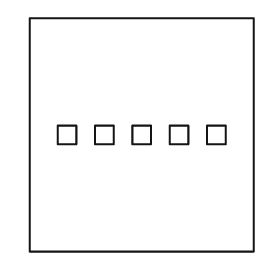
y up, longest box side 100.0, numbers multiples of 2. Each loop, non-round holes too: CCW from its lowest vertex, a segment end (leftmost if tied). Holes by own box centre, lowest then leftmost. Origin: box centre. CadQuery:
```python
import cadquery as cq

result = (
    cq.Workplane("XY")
    .moveTo(-48.0, -50.0)
    .lineTo(48.0, -50.0)
    .lineTo(48.0, 50.0)
    .lineTo(-48.0, 50.0)
    .close()
    .moveTo(-36.0, -4.0)
    .lineTo(-28.0, -4.0)
    .lineTo(-28.0, 4.0)
    .lineTo(-36.0, 4.0)
    .close()
    .moveTo(-20.0, -4.0)
    .lineTo(-12.0, -4.0)
    .lineTo(-12.0, 4.0)
    .lineTo(-20.0, 4.0)
    .close()
    .moveTo(-4.0, -4.0)
    .lineTo(4.0, -4.0)
    .lineTo(4.0, 4.0)
    .lineTo(-4.0, 4.0)
    .close()
    .moveTo(12.0, -4.0)
    .lineTo(20.0, -4.0)
    .lineTo(20.0, 4.0)
    .lineTo(12.0, 4.0)
    .close()
    .moveTo(28.0, -4.0)
    .lineTo(36.0, -4.0)
    .lineTo(36.0, 4.0)
    .lineTo(28.0, 4.0)
    .close()
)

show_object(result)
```